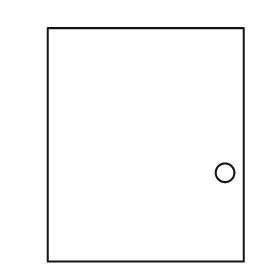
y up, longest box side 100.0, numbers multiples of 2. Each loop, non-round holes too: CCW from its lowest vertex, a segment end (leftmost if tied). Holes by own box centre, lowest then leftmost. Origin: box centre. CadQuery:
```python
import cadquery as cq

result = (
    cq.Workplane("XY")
    .moveTo(-42.0, -50.0)
    .lineTo(42.0, -50.0)
    .lineTo(42.0, 50.0)
    .lineTo(-42.0, 50.0)
    .close()
    .moveTo(34.0, -12.0)
    .circle(4.0)
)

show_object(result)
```